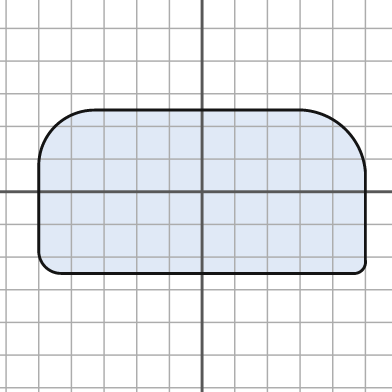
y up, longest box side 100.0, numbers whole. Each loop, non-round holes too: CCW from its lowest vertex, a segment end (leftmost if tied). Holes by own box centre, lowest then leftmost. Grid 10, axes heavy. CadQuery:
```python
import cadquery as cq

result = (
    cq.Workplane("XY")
    .moveTo(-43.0, -25.0)
    .lineTo(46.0, -25.0)
    .threePointArc((49.0, -24.0), (50.0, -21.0))
    .lineTo(50.0, 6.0)
    .threePointArc((44.0, 19.0), (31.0, 25.0))
    .lineTo(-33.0, 25.0)
    .threePointArc((-45.0, 20.0), (-50.0, 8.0))
    .lineTo(-50.0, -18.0)
    .threePointArc((-48.0, -23.0), (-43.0, -25.0))
    .close()
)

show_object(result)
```